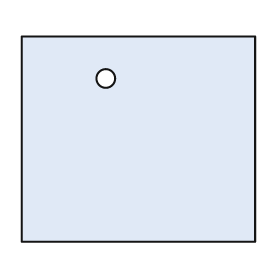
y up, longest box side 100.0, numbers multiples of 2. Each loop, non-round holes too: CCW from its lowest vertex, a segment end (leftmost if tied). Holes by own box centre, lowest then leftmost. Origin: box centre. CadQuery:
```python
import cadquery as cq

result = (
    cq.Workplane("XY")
    .moveTo(-50.0, -44.0)
    .lineTo(50.0, -44.0)
    .lineTo(50.0, 44.0)
    .lineTo(-50.0, 44.0)
    .close()
    .moveTo(-14.0, 26.0)
    .circle(4.0)
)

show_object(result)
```